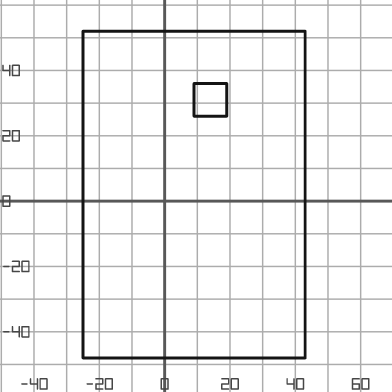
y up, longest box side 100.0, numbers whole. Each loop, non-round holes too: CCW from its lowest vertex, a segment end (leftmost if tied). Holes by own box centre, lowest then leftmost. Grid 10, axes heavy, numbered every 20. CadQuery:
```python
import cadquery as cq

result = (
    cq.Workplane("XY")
    .moveTo(-25.0, -48.0)
    .lineTo(43.0, -48.0)
    .lineTo(43.0, 52.0)
    .lineTo(-25.0, 52.0)
    .close()
    .moveTo(9.0, 26.0)
    .lineTo(19.0, 26.0)
    .lineTo(19.0, 36.0)
    .lineTo(9.0, 36.0)
    .close()
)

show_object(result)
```